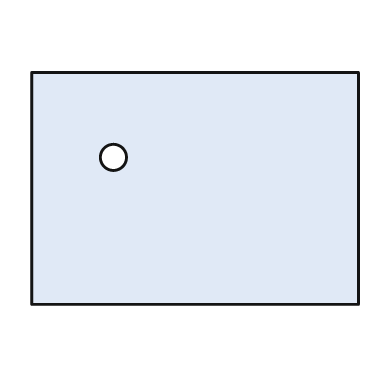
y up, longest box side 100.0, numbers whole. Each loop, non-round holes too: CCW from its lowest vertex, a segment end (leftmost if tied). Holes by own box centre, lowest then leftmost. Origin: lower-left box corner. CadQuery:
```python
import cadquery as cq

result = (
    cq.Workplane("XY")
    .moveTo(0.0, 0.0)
    .lineTo(100.0, 0.0)
    .lineTo(100.0, 71.0)
    .lineTo(0.0, 71.0)
    .close()
    .moveTo(25.0, 45.0)
    .circle(4.0)
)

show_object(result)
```